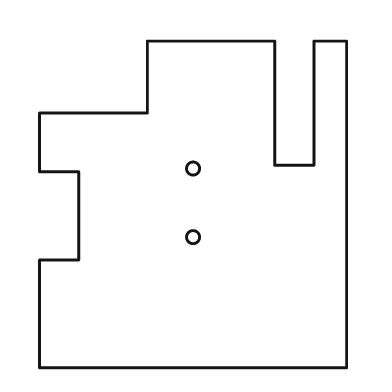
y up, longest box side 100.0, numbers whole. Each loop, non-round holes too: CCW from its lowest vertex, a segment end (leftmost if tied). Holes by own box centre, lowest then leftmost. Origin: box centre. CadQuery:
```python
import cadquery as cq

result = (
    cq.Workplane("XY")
    .moveTo(-47.0, -50.0)
    .lineTo(47.0, -50.0)
    .lineTo(47.0, 50.0)
    .lineTo(37.0, 50.0)
    .lineTo(37.0, 12.0)
    .lineTo(25.0, 12.0)
    .lineTo(25.0, 50.0)
    .lineTo(-14.0, 50.0)
    .lineTo(-14.0, 28.0)
    .lineTo(-47.0, 28.0)
    .lineTo(-47.0, 10.0)
    .lineTo(-35.0, 10.0)
    .lineTo(-35.0, -17.0)
    .lineTo(-47.0, -17.0)
    .close()
    .moveTo(0.0, -10.0)
    .circle(2.0)
    .moveTo(0.0, 11.0)
    .circle(2.0)
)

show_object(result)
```